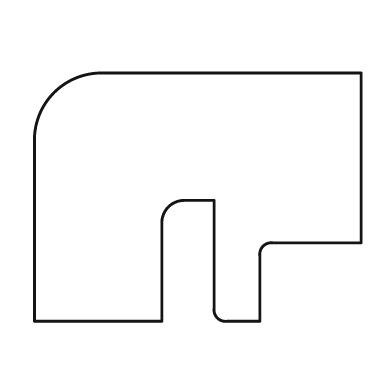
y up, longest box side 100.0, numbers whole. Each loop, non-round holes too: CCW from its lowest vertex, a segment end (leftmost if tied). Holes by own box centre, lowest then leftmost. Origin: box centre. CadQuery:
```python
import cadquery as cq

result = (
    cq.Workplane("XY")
    .moveTo(-50.0, -38.0)
    .lineTo(-11.0, -38.0)
    .lineTo(-11.0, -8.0)
    .threePointArc((-9.0, -3.0), (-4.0, -1.0))
    .lineTo(5.0, -1.0)
    .lineTo(5.0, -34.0)
    .threePointArc((6.0, -37.0), (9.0, -38.0))
    .lineTo(19.0, -38.0)
    .lineTo(19.0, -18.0)
    .threePointArc((20.0, -15.0), (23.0, -14.0))
    .lineTo(50.0, -14.0)
    .lineTo(50.0, 38.0)
    .lineTo(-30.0, 38.0)
    .threePointArc((-44.0, 32.0), (-50.0, 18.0))
    .close()
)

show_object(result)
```